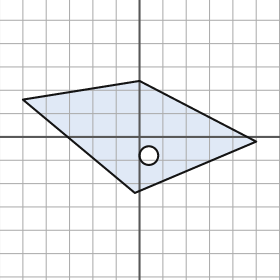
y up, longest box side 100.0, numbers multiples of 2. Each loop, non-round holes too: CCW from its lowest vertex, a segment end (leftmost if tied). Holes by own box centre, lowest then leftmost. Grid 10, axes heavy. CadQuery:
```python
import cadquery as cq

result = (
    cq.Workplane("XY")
    .moveTo(-2.0, -24.0)
    .lineTo(50.0, -2.0)
    .lineTo(0.0, 24.0)
    .lineTo(-50.0, 16.0)
    .close()
    .moveTo(4.0, -8.0)
    .circle(4.0)
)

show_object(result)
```